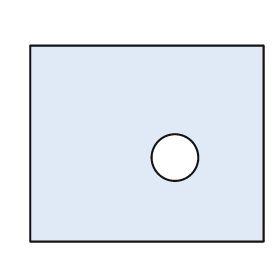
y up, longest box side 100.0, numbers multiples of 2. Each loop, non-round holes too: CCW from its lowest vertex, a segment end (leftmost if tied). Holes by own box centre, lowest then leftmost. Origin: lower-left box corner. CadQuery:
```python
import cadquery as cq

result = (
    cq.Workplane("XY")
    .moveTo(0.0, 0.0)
    .lineTo(100.0, 0.0)
    .lineTo(100.0, 84.0)
    .lineTo(0.0, 84.0)
    .close()
    .moveTo(62.0, 36.0)
    .circle(10.0)
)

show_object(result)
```